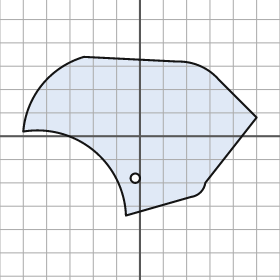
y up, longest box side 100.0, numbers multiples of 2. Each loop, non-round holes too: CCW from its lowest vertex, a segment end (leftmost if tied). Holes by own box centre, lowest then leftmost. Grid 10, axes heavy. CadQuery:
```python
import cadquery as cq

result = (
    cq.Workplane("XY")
    .moveTo(-6.0, -34.0)
    .lineTo(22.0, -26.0)
    .threePointArc((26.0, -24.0), (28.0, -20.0))
    .lineTo(50.0, 8.0)
    .lineTo(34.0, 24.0)
    .threePointArc((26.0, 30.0), (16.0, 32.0))
    .lineTo(-24.0, 34.0)
    .threePointArc((-42.0, 22.0), (-50.0, 2.0))
    .threePointArc((-20.0, -6.0), (-6.0, -34.0))
    .close()
    .moveTo(-2.0, -18.0)
    .circle(2.0)
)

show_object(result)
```